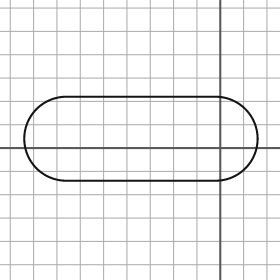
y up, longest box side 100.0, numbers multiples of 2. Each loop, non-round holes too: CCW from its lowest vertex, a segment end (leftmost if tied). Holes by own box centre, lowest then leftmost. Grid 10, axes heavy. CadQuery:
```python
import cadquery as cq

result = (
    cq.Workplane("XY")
    .moveTo(-66.0, -14.0)
    .lineTo(-2.0, -14.0)
    .threePointArc((16.0, 4.0), (-2.0, 22.0))
    .lineTo(-66.0, 22.0)
    .threePointArc((-84.0, 4.0), (-66.0, -14.0))
    .close()
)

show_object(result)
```